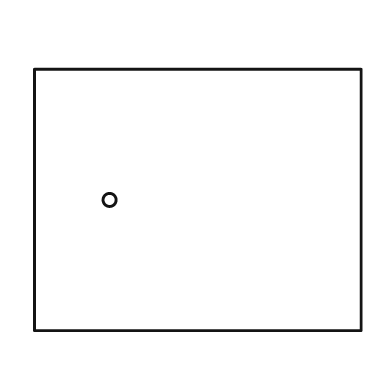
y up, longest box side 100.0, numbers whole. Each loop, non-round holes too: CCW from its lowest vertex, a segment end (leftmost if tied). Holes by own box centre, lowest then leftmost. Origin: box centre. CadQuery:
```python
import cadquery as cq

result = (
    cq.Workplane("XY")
    .moveTo(-50.0, -40.0)
    .lineTo(50.0, -40.0)
    .lineTo(50.0, 40.0)
    .lineTo(-50.0, 40.0)
    .close()
    .moveTo(-27.0, 0.0)
    .circle(2.0)
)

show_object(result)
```